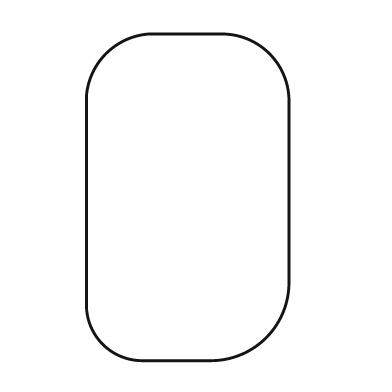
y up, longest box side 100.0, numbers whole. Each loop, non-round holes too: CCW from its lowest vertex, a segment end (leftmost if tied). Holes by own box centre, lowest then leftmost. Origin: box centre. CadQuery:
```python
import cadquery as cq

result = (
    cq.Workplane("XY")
    .moveTo(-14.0, -50.0)
    .lineTo(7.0, -50.0)
    .threePointArc((24.0, -43.0), (31.0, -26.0))
    .lineTo(31.0, 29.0)
    .threePointArc((25.0, 44.0), (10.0, 50.0))
    .lineTo(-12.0, 50.0)
    .threePointArc((-25.0, 44.0), (-31.0, 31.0))
    .lineTo(-31.0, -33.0)
    .threePointArc((-26.0, -45.0), (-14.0, -50.0))
    .close()
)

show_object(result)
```